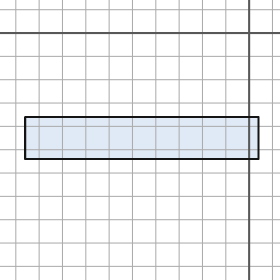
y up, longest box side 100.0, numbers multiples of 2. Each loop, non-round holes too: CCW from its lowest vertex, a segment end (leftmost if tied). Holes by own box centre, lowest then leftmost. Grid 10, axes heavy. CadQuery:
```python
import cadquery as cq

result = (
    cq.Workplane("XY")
    .moveTo(-96.0, -54.0)
    .lineTo(4.0, -54.0)
    .lineTo(4.0, -36.0)
    .lineTo(-96.0, -36.0)
    .close()
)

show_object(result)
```